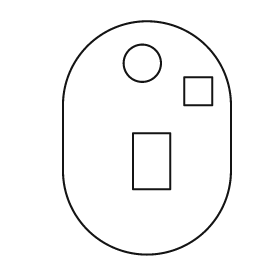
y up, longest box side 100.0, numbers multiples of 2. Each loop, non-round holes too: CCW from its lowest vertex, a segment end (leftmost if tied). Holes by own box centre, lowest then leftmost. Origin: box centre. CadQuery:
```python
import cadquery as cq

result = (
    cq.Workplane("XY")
    .moveTo(-36.0, -14.0)
    .threePointArc((0.0, -50.0), (36.0, -14.0))
    .lineTo(36.0, 14.0)
    .threePointArc((0.0, 50.0), (-36.0, 14.0))
    .close()
    .moveTo(-6.0, -22.0)
    .lineTo(10.0, -22.0)
    .lineTo(10.0, 2.0)
    .lineTo(-6.0, 2.0)
    .close()
    .moveTo(16.0, 14.0)
    .lineTo(28.0, 14.0)
    .lineTo(28.0, 26.0)
    .lineTo(16.0, 26.0)
    .close()
    .moveTo(-2.0, 32.0)
    .circle(8.0)
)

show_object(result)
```